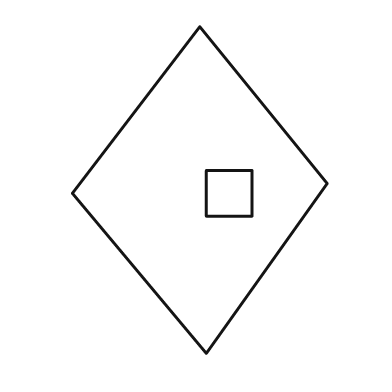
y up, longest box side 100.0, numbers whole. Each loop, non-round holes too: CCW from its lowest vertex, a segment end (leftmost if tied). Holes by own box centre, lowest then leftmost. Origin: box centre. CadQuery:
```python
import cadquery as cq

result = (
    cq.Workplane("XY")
    .moveTo(2.0, -50.0)
    .lineTo(39.0, 2.0)
    .lineTo(0.0, 50.0)
    .lineTo(-39.0, -1.0)
    .close()
    .moveTo(2.0, -8.0)
    .lineTo(16.0, -8.0)
    .lineTo(16.0, 6.0)
    .lineTo(2.0, 6.0)
    .close()
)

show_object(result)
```